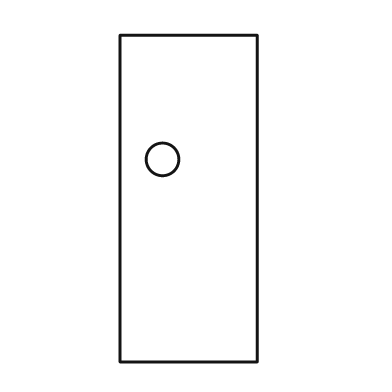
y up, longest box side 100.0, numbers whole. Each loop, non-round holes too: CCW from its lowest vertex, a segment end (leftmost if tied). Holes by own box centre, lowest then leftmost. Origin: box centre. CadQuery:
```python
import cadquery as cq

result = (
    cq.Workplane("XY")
    .moveTo(-21.0, -50.0)
    .lineTo(21.0, -50.0)
    .lineTo(21.0, 50.0)
    .lineTo(-21.0, 50.0)
    .close()
    .moveTo(-8.0, 12.0)
    .circle(5.0)
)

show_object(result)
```